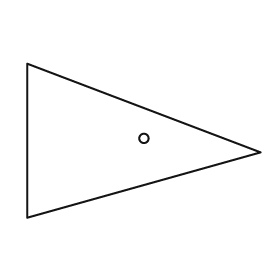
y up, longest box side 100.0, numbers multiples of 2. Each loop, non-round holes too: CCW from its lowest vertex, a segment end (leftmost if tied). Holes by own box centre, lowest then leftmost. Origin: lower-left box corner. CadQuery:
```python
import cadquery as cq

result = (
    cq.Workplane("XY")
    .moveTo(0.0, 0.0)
    .lineTo(100.0, 28.0)
    .lineTo(0.0, 66.0)
    .close()
    .moveTo(50.0, 34.0)
    .circle(2.0)
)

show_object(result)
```